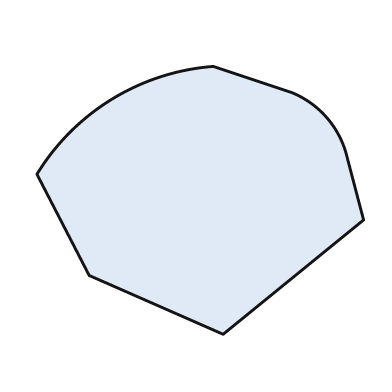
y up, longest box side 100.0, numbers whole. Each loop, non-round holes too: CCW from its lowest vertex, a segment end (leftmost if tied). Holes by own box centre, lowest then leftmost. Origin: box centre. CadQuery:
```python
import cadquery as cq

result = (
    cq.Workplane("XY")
    .moveTo(7.0, -41.0)
    .lineTo(50.0, -6.0)
    .lineTo(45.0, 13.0)
    .threePointArc((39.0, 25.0), (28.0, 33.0))
    .lineTo(4.0, 41.0)
    .threePointArc((-27.0, 31.0), (-50.0, 8.0))
    .lineTo(-34.0, -23.0)
    .close()
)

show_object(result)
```